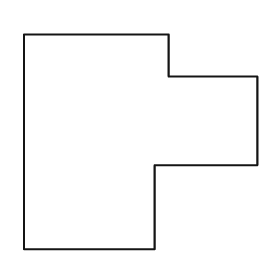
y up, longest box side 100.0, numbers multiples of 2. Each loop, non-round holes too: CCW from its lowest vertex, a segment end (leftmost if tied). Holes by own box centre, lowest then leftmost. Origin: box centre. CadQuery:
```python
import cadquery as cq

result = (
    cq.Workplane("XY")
    .moveTo(-50.0, -46.0)
    .lineTo(6.0, -46.0)
    .lineTo(6.0, -10.0)
    .lineTo(50.0, -10.0)
    .lineTo(50.0, 28.0)
    .lineTo(12.0, 28.0)
    .lineTo(12.0, 46.0)
    .lineTo(-50.0, 46.0)
    .close()
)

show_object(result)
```